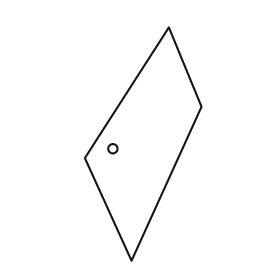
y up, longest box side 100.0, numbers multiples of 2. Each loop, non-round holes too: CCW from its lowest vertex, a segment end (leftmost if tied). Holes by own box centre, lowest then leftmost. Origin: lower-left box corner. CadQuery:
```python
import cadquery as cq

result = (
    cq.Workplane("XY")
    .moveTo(20.0, 0.0)
    .lineTo(50.0, 66.0)
    .lineTo(36.0, 100.0)
    .lineTo(0.0, 44.0)
    .close()
    .moveTo(12.0, 48.0)
    .circle(2.0)
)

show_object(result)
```